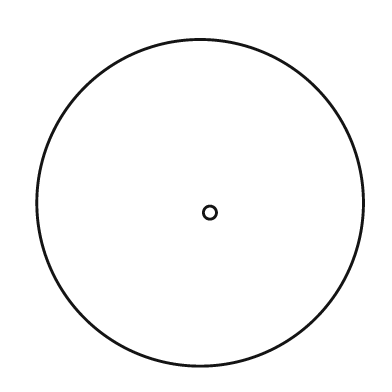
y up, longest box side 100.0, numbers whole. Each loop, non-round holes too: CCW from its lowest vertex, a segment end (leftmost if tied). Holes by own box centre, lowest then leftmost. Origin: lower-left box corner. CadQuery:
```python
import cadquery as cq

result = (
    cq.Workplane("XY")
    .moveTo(50.0, 50.0)
    .circle(50.0)
    .moveTo(53.0, 47.0)
    .circle(2.0)
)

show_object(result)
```